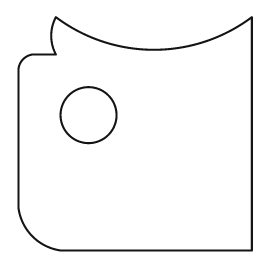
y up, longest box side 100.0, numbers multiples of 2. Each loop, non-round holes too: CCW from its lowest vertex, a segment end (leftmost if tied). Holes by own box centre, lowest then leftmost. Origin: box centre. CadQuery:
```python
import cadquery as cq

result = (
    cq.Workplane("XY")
    .moveTo(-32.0, -50.0)
    .lineTo(50.0, -50.0)
    .lineTo(50.0, 50.0)
    .threePointArc((8.0, 36.0), (-34.0, 50.0))
    .threePointArc((-36.0, 42.0), (-34.0, 34.0))
    .lineTo(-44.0, 34.0)
    .threePointArc((-48.0, 32.0), (-50.0, 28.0))
    .lineTo(-50.0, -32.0)
    .threePointArc((-44.0, -44.0), (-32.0, -50.0))
    .close()
    .moveTo(-20.0, 8.0)
    .circle(12.0)
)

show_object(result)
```